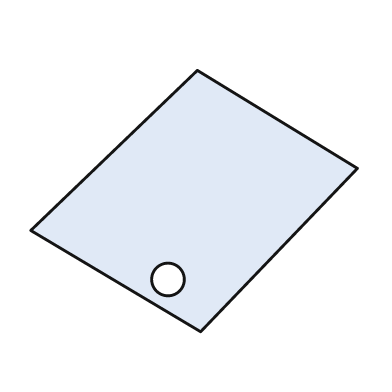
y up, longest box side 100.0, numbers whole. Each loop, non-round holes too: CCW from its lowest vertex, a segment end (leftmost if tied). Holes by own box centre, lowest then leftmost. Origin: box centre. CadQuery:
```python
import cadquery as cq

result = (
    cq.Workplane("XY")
    .moveTo(2.0, -40.0)
    .lineTo(50.0, 10.0)
    .lineTo(1.0, 40.0)
    .lineTo(-50.0, -9.0)
    .close()
    .moveTo(-8.0, -24.0)
    .circle(5.0)
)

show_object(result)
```